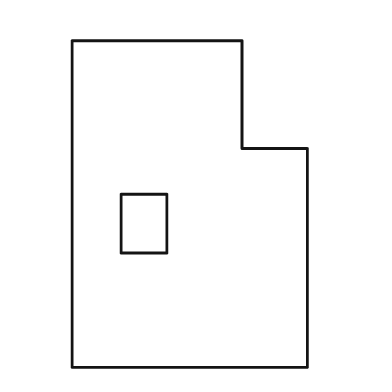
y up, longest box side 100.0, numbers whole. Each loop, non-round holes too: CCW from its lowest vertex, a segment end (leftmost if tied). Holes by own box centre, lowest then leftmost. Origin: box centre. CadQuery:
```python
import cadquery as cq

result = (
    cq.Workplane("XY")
    .moveTo(-36.0, -50.0)
    .lineTo(36.0, -50.0)
    .lineTo(36.0, 17.0)
    .lineTo(16.0, 17.0)
    .lineTo(16.0, 50.0)
    .lineTo(-36.0, 50.0)
    .close()
    .moveTo(-21.0, -15.0)
    .lineTo(-7.0, -15.0)
    .lineTo(-7.0, 3.0)
    .lineTo(-21.0, 3.0)
    .close()
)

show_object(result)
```